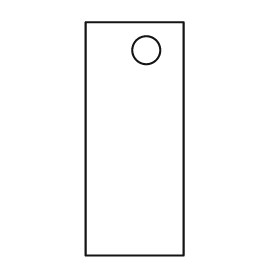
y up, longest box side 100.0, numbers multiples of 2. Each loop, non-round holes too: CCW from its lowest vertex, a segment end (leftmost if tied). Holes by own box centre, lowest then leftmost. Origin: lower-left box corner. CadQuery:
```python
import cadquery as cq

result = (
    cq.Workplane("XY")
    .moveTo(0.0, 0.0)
    .lineTo(42.0, 0.0)
    .lineTo(42.0, 100.0)
    .lineTo(0.0, 100.0)
    .close()
    .moveTo(26.0, 88.0)
    .circle(6.0)
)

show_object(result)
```